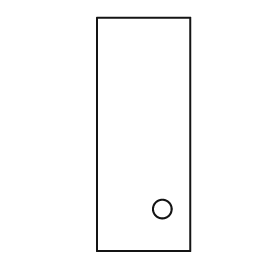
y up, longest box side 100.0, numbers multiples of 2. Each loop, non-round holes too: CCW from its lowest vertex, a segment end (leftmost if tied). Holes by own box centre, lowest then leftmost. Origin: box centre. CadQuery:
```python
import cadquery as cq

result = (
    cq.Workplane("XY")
    .moveTo(-20.0, -50.0)
    .lineTo(20.0, -50.0)
    .lineTo(20.0, 50.0)
    .lineTo(-20.0, 50.0)
    .close()
    .moveTo(8.0, -32.0)
    .circle(4.0)
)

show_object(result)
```